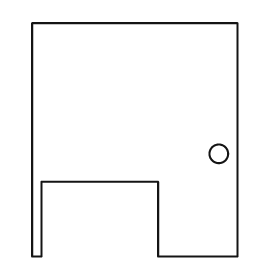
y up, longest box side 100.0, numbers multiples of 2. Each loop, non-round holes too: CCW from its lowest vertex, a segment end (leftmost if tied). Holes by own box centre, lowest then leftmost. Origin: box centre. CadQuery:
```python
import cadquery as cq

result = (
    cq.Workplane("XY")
    .moveTo(-44.0, -50.0)
    .lineTo(-40.0, -50.0)
    .lineTo(-40.0, -18.0)
    .lineTo(10.0, -18.0)
    .lineTo(10.0, -50.0)
    .lineTo(44.0, -50.0)
    .lineTo(44.0, 50.0)
    .lineTo(-44.0, 50.0)
    .close()
    .moveTo(36.0, -6.0)
    .circle(4.0)
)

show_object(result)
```